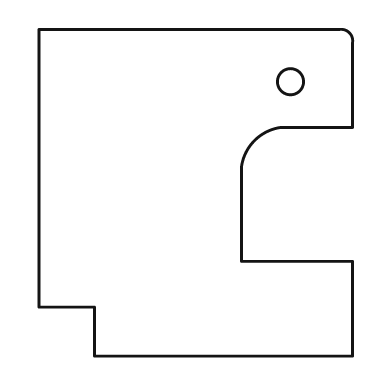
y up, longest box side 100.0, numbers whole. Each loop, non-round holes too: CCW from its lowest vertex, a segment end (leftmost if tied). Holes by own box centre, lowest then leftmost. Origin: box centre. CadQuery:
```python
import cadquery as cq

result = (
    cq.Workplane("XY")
    .moveTo(-31.0, -50.0)
    .lineTo(48.0, -50.0)
    .lineTo(48.0, -21.0)
    .lineTo(14.0, -21.0)
    .lineTo(14.0, 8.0)
    .threePointArc((18.0, 16.0), (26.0, 20.0))
    .lineTo(48.0, 20.0)
    .lineTo(48.0, 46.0)
    .threePointArc((47.0, 49.0), (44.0, 50.0))
    .lineTo(-48.0, 50.0)
    .lineTo(-48.0, -35.0)
    .lineTo(-31.0, -35.0)
    .close()
    .moveTo(29.0, 34.0)
    .circle(4.0)
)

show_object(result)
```